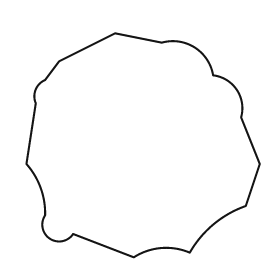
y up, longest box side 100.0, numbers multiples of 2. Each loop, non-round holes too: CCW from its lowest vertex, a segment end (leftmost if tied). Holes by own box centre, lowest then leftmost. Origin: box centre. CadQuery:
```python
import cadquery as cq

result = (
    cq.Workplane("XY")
    .moveTo(-4.0, -48.0)
    .threePointArc((8.0, -44.0), (20.0, -46.0))
    .threePointArc((30.0, -34.0), (44.0, -26.0))
    .lineTo(50.0, -8.0)
    .lineTo(42.0, 12.0)
    .threePointArc((40.0, 24.0), (30.0, 30.0))
    .threePointArc((22.0, 42.0), (8.0, 44.0))
    .lineTo(-12.0, 48.0)
    .lineTo(-36.0, 36.0)
    .lineTo(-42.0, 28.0)
    .threePointArc((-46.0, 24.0), (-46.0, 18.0))
    .lineTo(-50.0, -8.0)
    .threePointArc((-44.0, -18.0), (-42.0, -30.0))
    .threePointArc((-40.0, -40.0), (-30.0, -38.0))
    .close()
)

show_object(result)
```